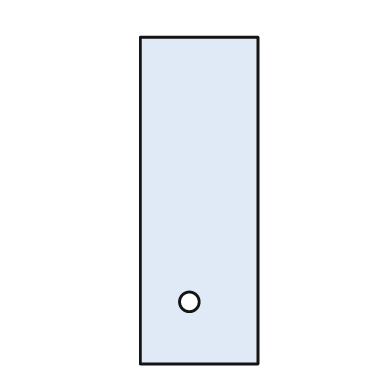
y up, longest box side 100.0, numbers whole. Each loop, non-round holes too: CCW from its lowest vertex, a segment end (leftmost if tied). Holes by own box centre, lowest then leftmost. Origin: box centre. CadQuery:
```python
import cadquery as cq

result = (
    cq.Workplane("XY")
    .moveTo(-18.0, -50.0)
    .lineTo(18.0, -50.0)
    .lineTo(18.0, 50.0)
    .lineTo(-18.0, 50.0)
    .close()
    .moveTo(-3.0, -31.0)
    .circle(3.0)
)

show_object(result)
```